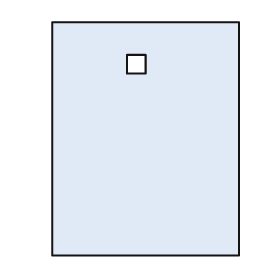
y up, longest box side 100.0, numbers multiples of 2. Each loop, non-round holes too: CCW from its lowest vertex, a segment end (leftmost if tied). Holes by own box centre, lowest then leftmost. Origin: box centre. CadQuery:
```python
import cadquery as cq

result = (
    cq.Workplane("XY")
    .moveTo(-40.0, -50.0)
    .lineTo(40.0, -50.0)
    .lineTo(40.0, 50.0)
    .lineTo(-40.0, 50.0)
    .close()
    .moveTo(-8.0, 28.0)
    .lineTo(0.0, 28.0)
    .lineTo(0.0, 36.0)
    .lineTo(-8.0, 36.0)
    .close()
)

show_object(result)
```